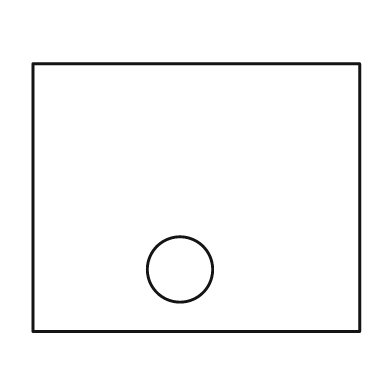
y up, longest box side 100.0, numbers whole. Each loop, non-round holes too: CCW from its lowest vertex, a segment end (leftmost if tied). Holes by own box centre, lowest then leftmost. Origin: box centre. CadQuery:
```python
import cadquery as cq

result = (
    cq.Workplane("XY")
    .moveTo(-50.0, -41.0)
    .lineTo(50.0, -41.0)
    .lineTo(50.0, 41.0)
    .lineTo(-50.0, 41.0)
    .close()
    .moveTo(-5.0, -22.0)
    .circle(10.0)
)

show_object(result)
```